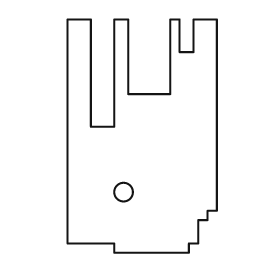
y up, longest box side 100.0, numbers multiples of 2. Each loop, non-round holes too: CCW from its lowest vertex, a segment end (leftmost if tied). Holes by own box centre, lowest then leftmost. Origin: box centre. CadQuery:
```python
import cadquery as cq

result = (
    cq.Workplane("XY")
    .moveTo(-12.0, -50.0)
    .lineTo(20.0, -50.0)
    .lineTo(20.0, -46.0)
    .lineTo(24.0, -46.0)
    .lineTo(24.0, -36.0)
    .lineTo(28.0, -36.0)
    .lineTo(28.0, -32.0)
    .lineTo(32.0, -32.0)
    .lineTo(32.0, 50.0)
    .lineTo(22.0, 50.0)
    .lineTo(22.0, 36.0)
    .lineTo(16.0, 36.0)
    .lineTo(16.0, 50.0)
    .lineTo(12.0, 50.0)
    .lineTo(12.0, 18.0)
    .lineTo(-6.0, 18.0)
    .lineTo(-6.0, 50.0)
    .lineTo(-12.0, 50.0)
    .lineTo(-12.0, 4.0)
    .lineTo(-22.0, 4.0)
    .lineTo(-22.0, 50.0)
    .lineTo(-32.0, 50.0)
    .lineTo(-32.0, -46.0)
    .lineTo(-12.0, -46.0)
    .close()
    .moveTo(-8.0, -24.0)
    .circle(4.0)
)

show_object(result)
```